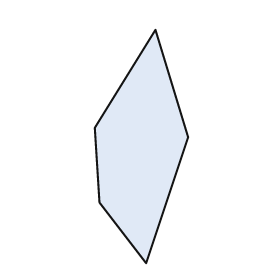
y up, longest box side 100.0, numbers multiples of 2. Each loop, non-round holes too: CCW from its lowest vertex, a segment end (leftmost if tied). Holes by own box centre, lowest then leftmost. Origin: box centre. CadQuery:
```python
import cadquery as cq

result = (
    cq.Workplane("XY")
    .moveTo(2.0, -50.0)
    .lineTo(20.0, 4.0)
    .lineTo(6.0, 50.0)
    .lineTo(-20.0, 8.0)
    .lineTo(-18.0, -24.0)
    .close()
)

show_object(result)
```